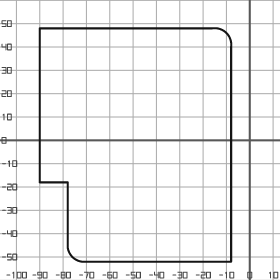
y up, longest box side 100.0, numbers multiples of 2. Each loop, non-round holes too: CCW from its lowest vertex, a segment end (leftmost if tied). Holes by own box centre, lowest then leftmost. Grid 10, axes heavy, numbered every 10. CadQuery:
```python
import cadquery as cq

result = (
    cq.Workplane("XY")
    .moveTo(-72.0, -52.0)
    .lineTo(-8.0, -52.0)
    .lineTo(-8.0, 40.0)
    .threePointArc((-10.0, 46.0), (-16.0, 48.0))
    .lineTo(-90.0, 48.0)
    .lineTo(-90.0, -18.0)
    .lineTo(-78.0, -18.0)
    .lineTo(-78.0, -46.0)
    .threePointArc((-76.0, -50.0), (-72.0, -52.0))
    .close()
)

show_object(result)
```